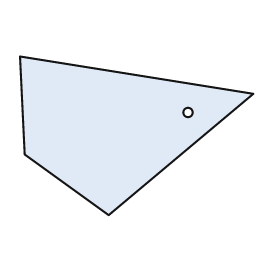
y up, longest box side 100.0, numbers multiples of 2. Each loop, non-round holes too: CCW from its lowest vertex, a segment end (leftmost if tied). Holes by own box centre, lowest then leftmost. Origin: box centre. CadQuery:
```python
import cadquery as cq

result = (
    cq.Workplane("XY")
    .moveTo(-12.0, -34.0)
    .lineTo(50.0, 18.0)
    .lineTo(-50.0, 34.0)
    .lineTo(-48.0, -8.0)
    .close()
    .moveTo(22.0, 10.0)
    .circle(2.0)
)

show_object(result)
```